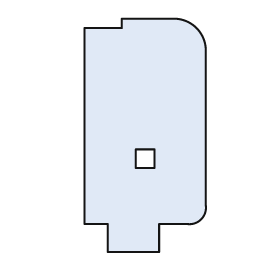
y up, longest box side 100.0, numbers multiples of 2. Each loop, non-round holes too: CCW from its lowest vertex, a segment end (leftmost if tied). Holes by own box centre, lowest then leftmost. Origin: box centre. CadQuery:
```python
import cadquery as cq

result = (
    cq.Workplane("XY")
    .moveTo(-16.0, -50.0)
    .lineTo(6.0, -50.0)
    .lineTo(6.0, -38.0)
    .lineTo(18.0, -38.0)
    .threePointArc((24.0, -36.0), (26.0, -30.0))
    .lineTo(26.0, 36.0)
    .threePointArc((22.0, 46.0), (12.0, 50.0))
    .lineTo(-10.0, 50.0)
    .lineTo(-10.0, 46.0)
    .lineTo(-26.0, 46.0)
    .lineTo(-26.0, -38.0)
    .lineTo(-16.0, -38.0)
    .close()
    .moveTo(-4.0, -14.0)
    .lineTo(4.0, -14.0)
    .lineTo(4.0, -6.0)
    .lineTo(-4.0, -6.0)
    .close()
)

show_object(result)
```